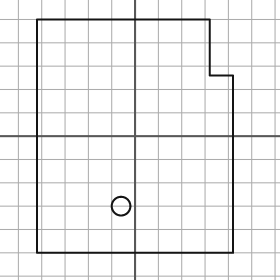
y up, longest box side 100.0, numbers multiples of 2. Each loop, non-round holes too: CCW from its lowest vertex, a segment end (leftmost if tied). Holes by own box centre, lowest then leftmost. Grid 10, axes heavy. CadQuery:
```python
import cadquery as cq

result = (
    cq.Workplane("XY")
    .moveTo(-42.0, -50.0)
    .lineTo(42.0, -50.0)
    .lineTo(42.0, 26.0)
    .lineTo(32.0, 26.0)
    .lineTo(32.0, 50.0)
    .lineTo(-42.0, 50.0)
    .close()
    .moveTo(-6.0, -30.0)
    .circle(4.0)
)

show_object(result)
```